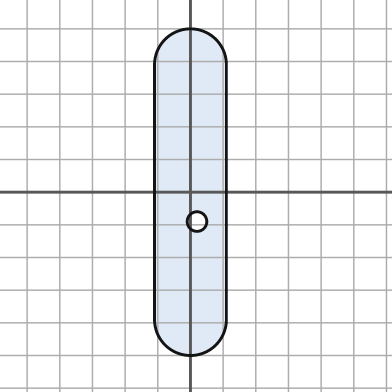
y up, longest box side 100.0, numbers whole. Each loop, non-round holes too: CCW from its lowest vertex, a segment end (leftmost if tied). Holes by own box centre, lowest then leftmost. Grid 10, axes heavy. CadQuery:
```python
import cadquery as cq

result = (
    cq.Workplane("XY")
    .moveTo(-11.0, -39.0)
    .threePointArc((0.0, -50.0), (11.0, -39.0))
    .lineTo(11.0, 39.0)
    .threePointArc((0.0, 50.0), (-11.0, 39.0))
    .close()
    .moveTo(2.0, -9.0)
    .circle(3.0)
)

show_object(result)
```